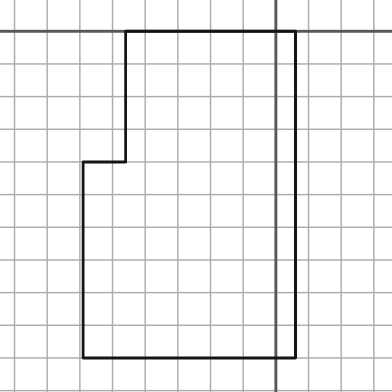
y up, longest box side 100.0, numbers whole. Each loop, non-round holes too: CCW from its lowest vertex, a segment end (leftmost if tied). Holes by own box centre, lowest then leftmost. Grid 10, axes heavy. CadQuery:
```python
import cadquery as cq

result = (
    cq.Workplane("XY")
    .moveTo(-59.0, -100.0)
    .lineTo(6.0, -100.0)
    .lineTo(6.0, 0.0)
    .lineTo(-46.0, 0.0)
    .lineTo(-46.0, -40.0)
    .lineTo(-59.0, -40.0)
    .close()
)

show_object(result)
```